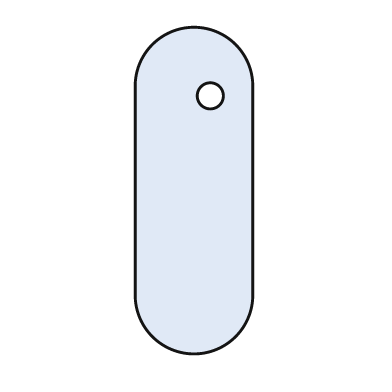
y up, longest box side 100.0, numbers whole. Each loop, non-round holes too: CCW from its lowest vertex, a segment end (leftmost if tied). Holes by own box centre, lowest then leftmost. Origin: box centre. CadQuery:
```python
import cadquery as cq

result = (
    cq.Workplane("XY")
    .moveTo(-18.0, -32.0)
    .threePointArc((0.0, -50.0), (18.0, -32.0))
    .lineTo(18.0, 32.0)
    .threePointArc((0.0, 50.0), (-18.0, 32.0))
    .close()
    .moveTo(5.0, 29.0)
    .circle(4.0)
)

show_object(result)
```